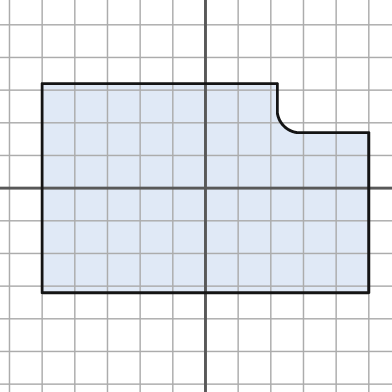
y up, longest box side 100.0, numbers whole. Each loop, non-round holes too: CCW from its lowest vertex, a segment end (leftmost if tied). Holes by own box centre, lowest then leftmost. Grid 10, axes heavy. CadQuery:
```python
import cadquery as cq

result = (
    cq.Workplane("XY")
    .moveTo(-50.0, -32.0)
    .lineTo(50.0, -32.0)
    .lineTo(50.0, 17.0)
    .lineTo(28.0, 17.0)
    .threePointArc((24.0, 19.0), (22.0, 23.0))
    .lineTo(22.0, 32.0)
    .lineTo(-50.0, 32.0)
    .close()
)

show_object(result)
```